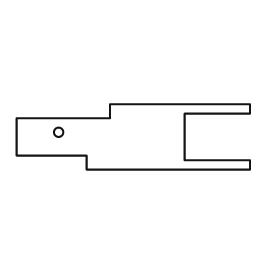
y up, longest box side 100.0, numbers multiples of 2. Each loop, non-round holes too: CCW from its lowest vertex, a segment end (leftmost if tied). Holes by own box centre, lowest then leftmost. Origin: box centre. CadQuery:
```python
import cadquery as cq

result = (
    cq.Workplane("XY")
    .moveTo(-20.0, -14.0)
    .lineTo(50.0, -14.0)
    .lineTo(50.0, -10.0)
    .lineTo(22.0, -10.0)
    .lineTo(22.0, 10.0)
    .lineTo(50.0, 10.0)
    .lineTo(50.0, 14.0)
    .lineTo(-10.0, 14.0)
    .lineTo(-10.0, 8.0)
    .lineTo(-50.0, 8.0)
    .lineTo(-50.0, -8.0)
    .lineTo(-20.0, -8.0)
    .close()
    .moveTo(-32.0, 2.0)
    .circle(2.0)
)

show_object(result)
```